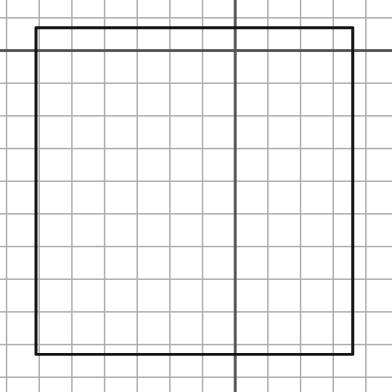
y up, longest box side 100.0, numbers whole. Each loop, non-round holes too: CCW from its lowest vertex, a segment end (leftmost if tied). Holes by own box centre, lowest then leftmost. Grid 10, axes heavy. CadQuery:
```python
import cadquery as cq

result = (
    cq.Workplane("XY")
    .moveTo(-61.0, -93.0)
    .lineTo(36.0, -93.0)
    .lineTo(36.0, 7.0)
    .lineTo(-61.0, 7.0)
    .close()
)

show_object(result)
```